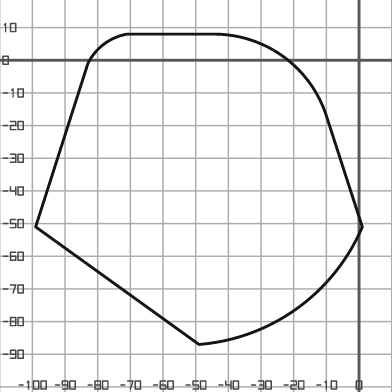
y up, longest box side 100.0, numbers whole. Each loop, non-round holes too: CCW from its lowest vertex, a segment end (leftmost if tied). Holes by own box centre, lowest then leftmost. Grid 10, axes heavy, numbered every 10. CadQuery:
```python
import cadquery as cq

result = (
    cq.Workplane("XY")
    .moveTo(-49.0, -87.0)
    .threePointArc((-19.0, -76.0), (1.0, -51.0))
    .lineTo(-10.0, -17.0)
    .threePointArc((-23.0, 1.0), (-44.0, 8.0))
    .lineTo(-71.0, 8.0)
    .threePointArc((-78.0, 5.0), (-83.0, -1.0))
    .lineTo(-99.0, -51.0)
    .close()
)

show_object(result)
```